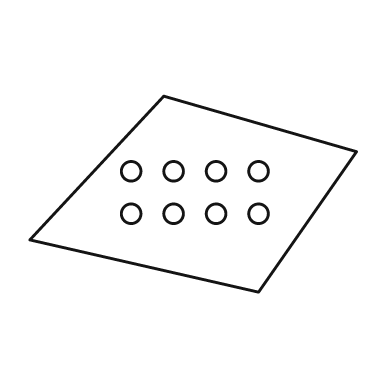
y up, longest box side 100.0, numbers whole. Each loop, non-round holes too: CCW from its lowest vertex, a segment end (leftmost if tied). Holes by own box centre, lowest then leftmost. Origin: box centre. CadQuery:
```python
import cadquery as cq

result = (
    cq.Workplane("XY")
    .moveTo(20.0, -30.0)
    .lineTo(50.0, 13.0)
    .lineTo(-9.0, 30.0)
    .lineTo(-50.0, -14.0)
    .close()
    .moveTo(-19.0, -6.0)
    .circle(3.0)
    .moveTo(-6.0, -6.0)
    .circle(3.0)
    .moveTo(7.0, -6.0)
    .circle(3.0)
    .moveTo(20.0, -6.0)
    .circle(3.0)
    .moveTo(-19.0, 7.0)
    .circle(3.0)
    .moveTo(-6.0, 7.0)
    .circle(3.0)
    .moveTo(7.0, 7.0)
    .circle(3.0)
    .moveTo(20.0, 7.0)
    .circle(3.0)
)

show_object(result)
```